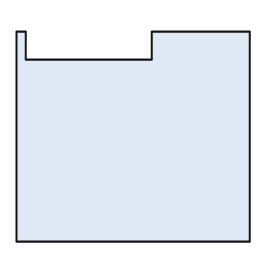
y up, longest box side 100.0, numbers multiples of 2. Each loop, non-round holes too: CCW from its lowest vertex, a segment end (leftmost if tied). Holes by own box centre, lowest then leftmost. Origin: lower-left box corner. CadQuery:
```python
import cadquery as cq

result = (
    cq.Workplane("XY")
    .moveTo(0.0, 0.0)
    .lineTo(100.0, 0.0)
    .lineTo(100.0, 90.0)
    .lineTo(58.0, 90.0)
    .lineTo(58.0, 78.0)
    .lineTo(4.0, 78.0)
    .lineTo(4.0, 90.0)
    .lineTo(0.0, 90.0)
    .close()
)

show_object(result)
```